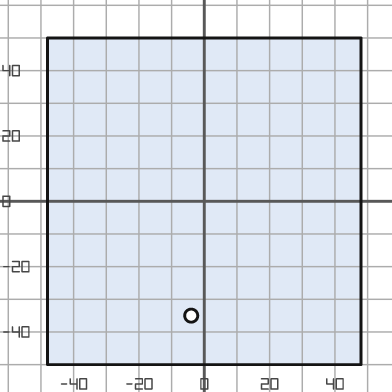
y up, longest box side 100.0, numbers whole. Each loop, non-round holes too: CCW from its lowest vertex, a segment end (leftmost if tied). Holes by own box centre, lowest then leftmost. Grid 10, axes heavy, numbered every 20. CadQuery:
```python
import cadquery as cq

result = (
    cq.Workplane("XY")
    .moveTo(-48.0, -50.0)
    .lineTo(48.0, -50.0)
    .lineTo(48.0, 50.0)
    .lineTo(-48.0, 50.0)
    .close()
    .moveTo(-4.0, -35.0)
    .circle(2.0)
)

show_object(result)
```